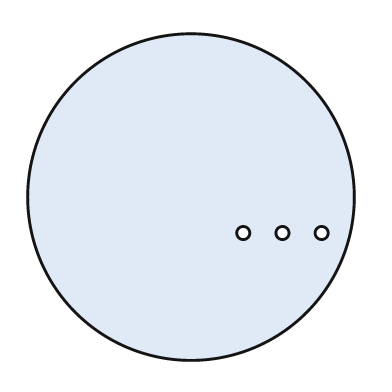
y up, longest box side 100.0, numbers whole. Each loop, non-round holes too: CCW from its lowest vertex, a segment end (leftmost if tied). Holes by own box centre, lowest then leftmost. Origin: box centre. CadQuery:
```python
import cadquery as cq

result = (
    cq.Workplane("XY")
    .moveTo(0.0, 0.0)
    .circle(50.0)
    .moveTo(16.0, -11.0)
    .circle(2.0)
    .moveTo(28.0, -11.0)
    .circle(2.0)
    .moveTo(40.0, -11.0)
    .circle(2.0)
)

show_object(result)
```